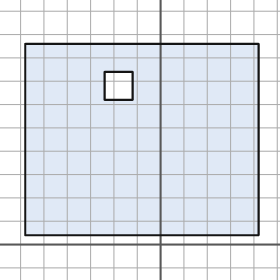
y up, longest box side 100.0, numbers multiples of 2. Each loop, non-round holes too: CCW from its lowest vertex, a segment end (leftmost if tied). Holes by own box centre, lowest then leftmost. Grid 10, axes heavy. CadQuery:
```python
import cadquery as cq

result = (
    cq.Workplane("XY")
    .moveTo(-58.0, 4.0)
    .lineTo(42.0, 4.0)
    .lineTo(42.0, 86.0)
    .lineTo(-58.0, 86.0)
    .close()
    .moveTo(-24.0, 62.0)
    .lineTo(-12.0, 62.0)
    .lineTo(-12.0, 74.0)
    .lineTo(-24.0, 74.0)
    .close()
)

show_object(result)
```